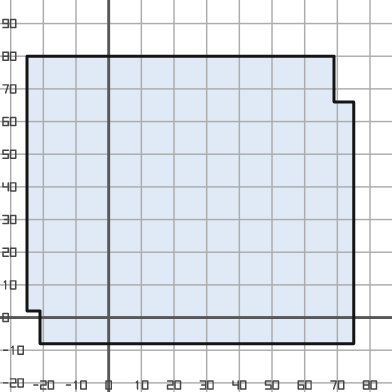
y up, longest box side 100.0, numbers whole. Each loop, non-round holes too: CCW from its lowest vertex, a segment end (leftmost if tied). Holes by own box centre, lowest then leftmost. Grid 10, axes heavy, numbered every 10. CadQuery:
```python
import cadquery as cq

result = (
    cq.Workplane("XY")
    .moveTo(-21.0, -8.0)
    .lineTo(75.0, -8.0)
    .lineTo(75.0, 66.0)
    .lineTo(69.0, 66.0)
    .lineTo(69.0, 80.0)
    .lineTo(-25.0, 80.0)
    .lineTo(-25.0, 2.0)
    .lineTo(-21.0, 2.0)
    .close()
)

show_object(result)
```